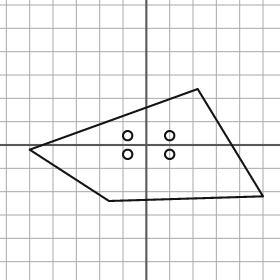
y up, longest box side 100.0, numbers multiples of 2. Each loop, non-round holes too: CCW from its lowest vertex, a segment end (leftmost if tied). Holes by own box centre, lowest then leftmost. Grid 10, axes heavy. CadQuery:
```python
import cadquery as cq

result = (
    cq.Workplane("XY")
    .moveTo(-16.0, -24.0)
    .lineTo(50.0, -22.0)
    .lineTo(22.0, 24.0)
    .lineTo(-50.0, -2.0)
    .close()
    .moveTo(-8.0, -4.0)
    .circle(2.0)
    .moveTo(10.0, -4.0)
    .circle(2.0)
    .moveTo(-8.0, 4.0)
    .circle(2.0)
    .moveTo(10.0, 4.0)
    .circle(2.0)
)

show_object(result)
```